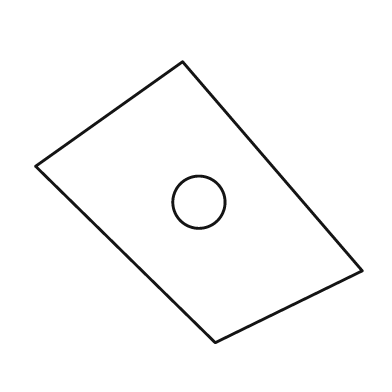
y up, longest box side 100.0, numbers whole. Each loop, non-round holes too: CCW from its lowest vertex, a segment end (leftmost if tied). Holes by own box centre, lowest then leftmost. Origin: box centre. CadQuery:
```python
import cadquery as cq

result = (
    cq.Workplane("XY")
    .moveTo(5.0, -43.0)
    .lineTo(50.0, -21.0)
    .lineTo(-5.0, 43.0)
    .lineTo(-50.0, 11.0)
    .close()
    .moveTo(0.0, 0.0)
    .circle(8.0)
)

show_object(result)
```